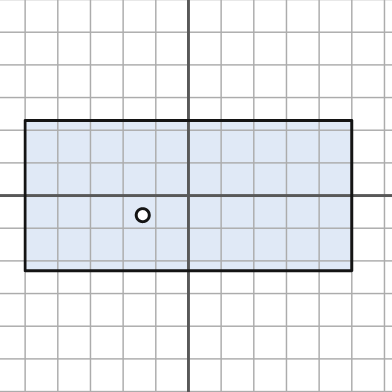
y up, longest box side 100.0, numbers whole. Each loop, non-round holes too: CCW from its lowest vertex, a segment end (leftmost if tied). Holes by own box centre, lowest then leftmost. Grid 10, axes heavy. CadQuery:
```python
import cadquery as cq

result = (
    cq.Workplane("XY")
    .moveTo(-50.0, -23.0)
    .lineTo(50.0, -23.0)
    .lineTo(50.0, 23.0)
    .lineTo(-50.0, 23.0)
    .close()
    .moveTo(-14.0, -6.0)
    .circle(2.0)
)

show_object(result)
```